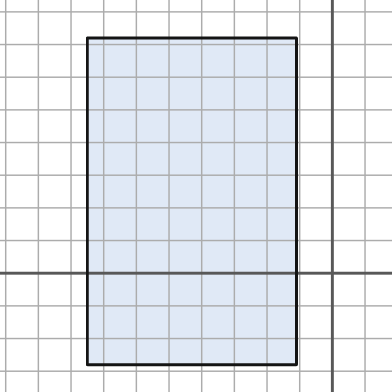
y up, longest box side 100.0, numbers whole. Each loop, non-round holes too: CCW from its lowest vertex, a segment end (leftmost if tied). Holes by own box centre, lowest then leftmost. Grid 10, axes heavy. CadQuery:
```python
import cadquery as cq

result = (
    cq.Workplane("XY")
    .moveTo(-75.0, -28.0)
    .lineTo(-11.0, -28.0)
    .lineTo(-11.0, 72.0)
    .lineTo(-75.0, 72.0)
    .close()
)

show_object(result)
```